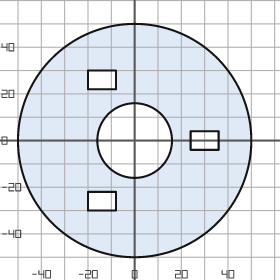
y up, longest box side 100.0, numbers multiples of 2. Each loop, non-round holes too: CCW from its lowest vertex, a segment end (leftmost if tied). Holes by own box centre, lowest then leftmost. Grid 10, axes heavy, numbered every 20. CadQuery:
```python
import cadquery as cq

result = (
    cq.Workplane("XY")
    .moveTo(0.0, 0.0)
    .circle(50.0)
    .moveTo(-20.0, -30.0)
    .lineTo(-8.0, -30.0)
    .lineTo(-8.0, -22.0)
    .lineTo(-20.0, -22.0)
    .close()
    .moveTo(0.0, 0.0)
    .circle(16.0)
    .moveTo(24.0, -4.0)
    .lineTo(36.0, -4.0)
    .lineTo(36.0, 4.0)
    .lineTo(24.0, 4.0)
    .close()
    .moveTo(-20.0, 22.0)
    .lineTo(-8.0, 22.0)
    .lineTo(-8.0, 30.0)
    .lineTo(-20.0, 30.0)
    .close()
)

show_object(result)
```